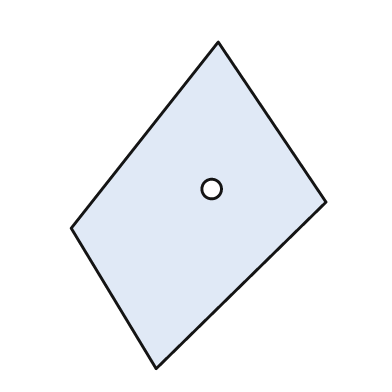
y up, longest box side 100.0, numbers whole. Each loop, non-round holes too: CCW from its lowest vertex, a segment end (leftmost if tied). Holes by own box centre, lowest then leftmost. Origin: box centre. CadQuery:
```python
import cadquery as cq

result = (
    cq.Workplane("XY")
    .moveTo(-13.0, -50.0)
    .lineTo(39.0, 1.0)
    .lineTo(6.0, 50.0)
    .lineTo(-39.0, -7.0)
    .close()
    .moveTo(4.0, 5.0)
    .circle(3.0)
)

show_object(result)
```